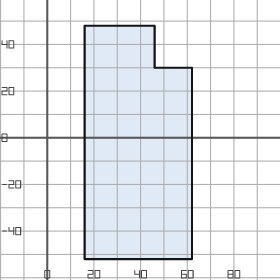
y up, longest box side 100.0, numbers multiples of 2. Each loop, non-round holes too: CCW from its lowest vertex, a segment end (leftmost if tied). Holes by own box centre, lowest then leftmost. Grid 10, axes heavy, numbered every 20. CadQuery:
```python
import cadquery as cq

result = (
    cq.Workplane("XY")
    .moveTo(16.0, -52.0)
    .lineTo(62.0, -52.0)
    .lineTo(62.0, 30.0)
    .lineTo(46.0, 30.0)
    .lineTo(46.0, 48.0)
    .lineTo(16.0, 48.0)
    .close()
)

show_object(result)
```